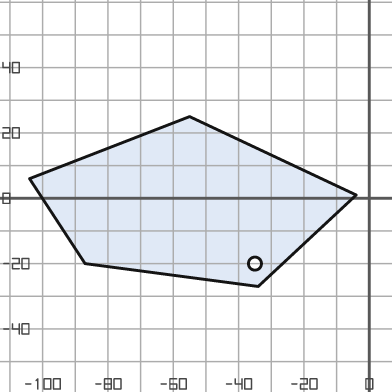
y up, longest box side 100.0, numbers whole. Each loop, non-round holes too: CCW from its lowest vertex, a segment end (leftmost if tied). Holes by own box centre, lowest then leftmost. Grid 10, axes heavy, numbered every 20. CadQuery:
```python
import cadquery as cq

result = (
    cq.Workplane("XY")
    .moveTo(-34.0, -27.0)
    .lineTo(-4.0, 1.0)
    .lineTo(-55.0, 25.0)
    .lineTo(-104.0, 6.0)
    .lineTo(-87.0, -20.0)
    .close()
    .moveTo(-35.0, -20.0)
    .circle(2.0)
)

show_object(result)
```